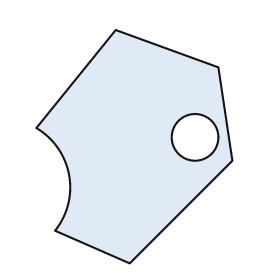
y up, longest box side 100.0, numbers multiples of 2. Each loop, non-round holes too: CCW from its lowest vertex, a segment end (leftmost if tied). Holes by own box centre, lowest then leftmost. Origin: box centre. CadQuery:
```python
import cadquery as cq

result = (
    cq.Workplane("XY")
    .moveTo(-2.0, -50.0)
    .lineTo(42.0, -6.0)
    .lineTo(36.0, 34.0)
    .lineTo(-8.0, 50.0)
    .lineTo(-42.0, 8.0)
    .threePointArc((-28.0, -12.0), (-34.0, -36.0))
    .close()
    .moveTo(26.0, 4.0)
    .circle(10.0)
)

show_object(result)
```